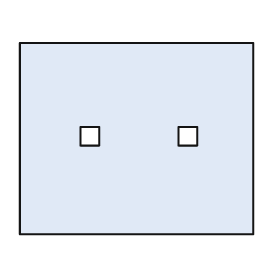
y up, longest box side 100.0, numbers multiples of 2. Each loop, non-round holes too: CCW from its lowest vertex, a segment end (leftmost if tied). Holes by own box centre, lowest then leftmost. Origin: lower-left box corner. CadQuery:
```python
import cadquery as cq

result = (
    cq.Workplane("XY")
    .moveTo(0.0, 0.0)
    .lineTo(100.0, 0.0)
    .lineTo(100.0, 82.0)
    .lineTo(0.0, 82.0)
    .close()
    .moveTo(26.0, 38.0)
    .lineTo(34.0, 38.0)
    .lineTo(34.0, 46.0)
    .lineTo(26.0, 46.0)
    .close()
    .moveTo(68.0, 38.0)
    .lineTo(76.0, 38.0)
    .lineTo(76.0, 46.0)
    .lineTo(68.0, 46.0)
    .close()
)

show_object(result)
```